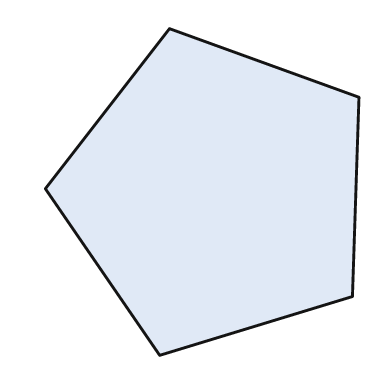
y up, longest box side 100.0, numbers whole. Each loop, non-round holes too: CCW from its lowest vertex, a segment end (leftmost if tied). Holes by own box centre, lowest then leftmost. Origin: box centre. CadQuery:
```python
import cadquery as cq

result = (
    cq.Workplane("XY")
    .moveTo(-13.0, -50.0)
    .lineTo(46.0, -32.0)
    .lineTo(48.0, 29.0)
    .lineTo(-10.0, 50.0)
    .lineTo(-48.0, 1.0)
    .close()
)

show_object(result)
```